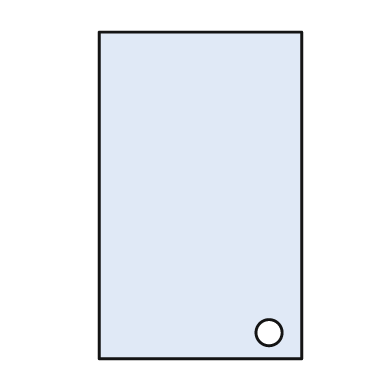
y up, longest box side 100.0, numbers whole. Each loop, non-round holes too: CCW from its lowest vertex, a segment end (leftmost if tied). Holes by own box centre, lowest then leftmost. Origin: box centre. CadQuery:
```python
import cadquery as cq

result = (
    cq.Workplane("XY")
    .moveTo(-31.0, -50.0)
    .lineTo(31.0, -50.0)
    .lineTo(31.0, 50.0)
    .lineTo(-31.0, 50.0)
    .close()
    .moveTo(21.0, -42.0)
    .circle(4.0)
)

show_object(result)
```